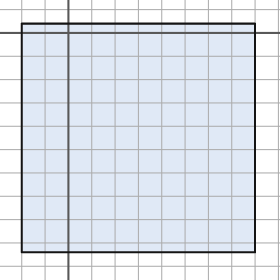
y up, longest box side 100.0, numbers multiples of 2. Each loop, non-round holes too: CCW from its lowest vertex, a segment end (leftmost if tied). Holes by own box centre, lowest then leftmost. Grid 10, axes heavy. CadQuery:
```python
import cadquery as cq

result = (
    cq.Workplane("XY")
    .moveTo(-20.0, -94.0)
    .lineTo(80.0, -94.0)
    .lineTo(80.0, 4.0)
    .lineTo(-20.0, 4.0)
    .close()
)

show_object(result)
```